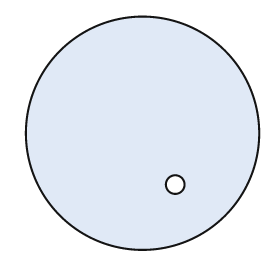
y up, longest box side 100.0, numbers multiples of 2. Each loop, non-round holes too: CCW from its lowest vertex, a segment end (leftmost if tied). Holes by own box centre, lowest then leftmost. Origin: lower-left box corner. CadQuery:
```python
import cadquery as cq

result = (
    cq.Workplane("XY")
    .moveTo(50.0, 50.0)
    .circle(50.0)
    .moveTo(64.0, 28.0)
    .circle(4.0)
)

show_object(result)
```